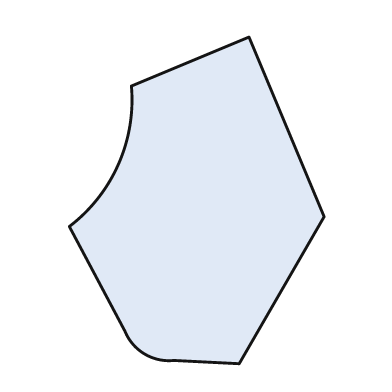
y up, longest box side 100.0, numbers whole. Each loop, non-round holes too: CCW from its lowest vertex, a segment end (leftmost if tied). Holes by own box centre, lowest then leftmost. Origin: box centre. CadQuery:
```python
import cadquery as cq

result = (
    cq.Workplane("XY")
    .moveTo(13.0, -50.0)
    .lineTo(39.0, -5.0)
    .lineTo(16.0, 50.0)
    .lineTo(-20.0, 35.0)
    .threePointArc((-24.0, 11.0), (-39.0, -8.0))
    .lineTo(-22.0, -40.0)
    .threePointArc((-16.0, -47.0), (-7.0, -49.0))
    .close()
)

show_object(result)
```